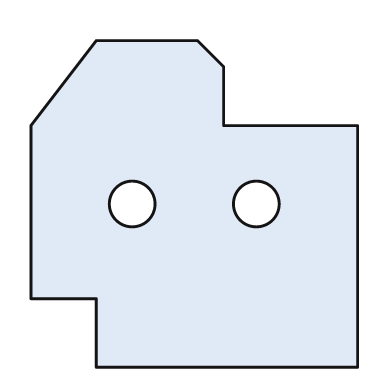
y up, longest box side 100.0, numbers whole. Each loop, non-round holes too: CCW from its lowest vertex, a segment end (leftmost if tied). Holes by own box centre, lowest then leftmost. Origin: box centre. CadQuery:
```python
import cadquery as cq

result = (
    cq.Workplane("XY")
    .moveTo(-30.0, -50.0)
    .lineTo(50.0, -50.0)
    .lineTo(50.0, 24.0)
    .lineTo(9.0, 24.0)
    .lineTo(9.0, 42.0)
    .lineTo(1.0, 50.0)
    .lineTo(-30.0, 50.0)
    .lineTo(-50.0, 24.0)
    .lineTo(-50.0, -29.0)
    .lineTo(-30.0, -29.0)
    .close()
    .moveTo(-19.0, 0.0)
    .circle(7.0)
    .moveTo(19.0, 0.0)
    .circle(7.0)
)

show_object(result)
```